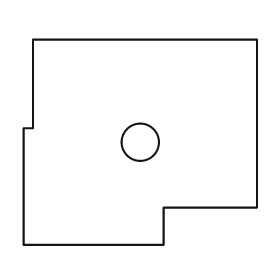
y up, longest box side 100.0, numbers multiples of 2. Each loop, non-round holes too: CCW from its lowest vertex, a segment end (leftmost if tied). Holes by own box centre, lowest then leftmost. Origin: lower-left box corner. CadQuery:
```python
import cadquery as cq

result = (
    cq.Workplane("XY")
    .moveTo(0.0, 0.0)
    .lineTo(60.0, 0.0)
    .lineTo(60.0, 16.0)
    .lineTo(100.0, 16.0)
    .lineTo(100.0, 88.0)
    .lineTo(4.0, 88.0)
    .lineTo(4.0, 50.0)
    .lineTo(0.0, 50.0)
    .close()
    .moveTo(50.0, 44.0)
    .circle(8.0)
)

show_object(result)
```